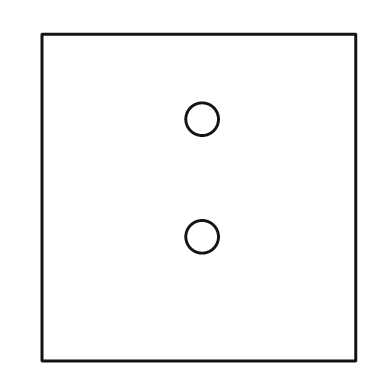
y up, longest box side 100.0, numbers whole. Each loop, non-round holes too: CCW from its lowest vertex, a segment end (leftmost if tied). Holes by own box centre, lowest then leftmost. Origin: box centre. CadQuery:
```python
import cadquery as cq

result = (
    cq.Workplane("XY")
    .moveTo(-48.0, -50.0)
    .lineTo(48.0, -50.0)
    .lineTo(48.0, 50.0)
    .lineTo(-48.0, 50.0)
    .close()
    .moveTo(1.0, -12.0)
    .circle(5.0)
    .moveTo(1.0, 24.0)
    .circle(5.0)
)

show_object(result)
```